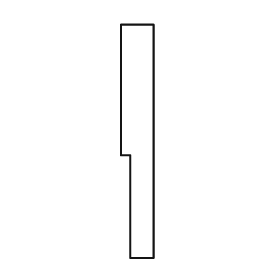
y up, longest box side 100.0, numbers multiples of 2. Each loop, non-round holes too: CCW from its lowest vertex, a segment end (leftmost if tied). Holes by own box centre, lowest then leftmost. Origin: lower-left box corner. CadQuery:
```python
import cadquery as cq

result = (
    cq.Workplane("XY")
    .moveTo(4.0, 0.0)
    .lineTo(14.0, 0.0)
    .lineTo(14.0, 100.0)
    .lineTo(0.0, 100.0)
    .lineTo(0.0, 44.0)
    .lineTo(4.0, 44.0)
    .close()
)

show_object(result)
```